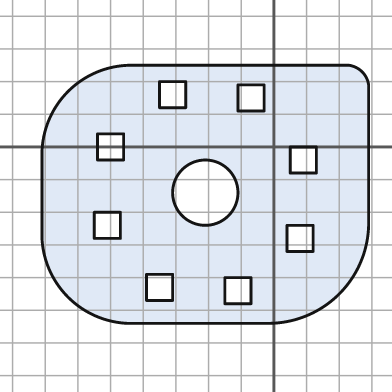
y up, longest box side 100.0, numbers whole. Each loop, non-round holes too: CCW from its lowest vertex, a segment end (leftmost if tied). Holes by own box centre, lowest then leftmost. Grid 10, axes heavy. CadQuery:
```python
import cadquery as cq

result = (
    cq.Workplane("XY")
    .moveTo(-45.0, -54.0)
    .lineTo(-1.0, -54.0)
    .threePointArc((20.0, -45.0), (29.0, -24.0))
    .lineTo(29.0, 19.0)
    .threePointArc((27.0, 23.0), (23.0, 25.0))
    .lineTo(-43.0, 25.0)
    .threePointArc((-63.0, 17.0), (-71.0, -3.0))
    .lineTo(-71.0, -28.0)
    .threePointArc((-63.0, -46.0), (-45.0, -54.0))
    .close()
    .moveTo(-15.0, -48.0)
    .lineTo(-7.0, -48.0)
    .lineTo(-7.0, -40.0)
    .lineTo(-15.0, -40.0)
    .close()
    .moveTo(-39.0, -47.0)
    .lineTo(-31.0, -47.0)
    .lineTo(-31.0, -39.0)
    .lineTo(-39.0, -39.0)
    .close()
    .moveTo(4.0, -32.0)
    .lineTo(12.0, -32.0)
    .lineTo(12.0, -24.0)
    .lineTo(4.0, -24.0)
    .close()
    .moveTo(-55.0, -28.0)
    .lineTo(-47.0, -28.0)
    .lineTo(-47.0, -20.0)
    .lineTo(-55.0, -20.0)
    .close()
    .moveTo(-21.0, -14.0)
    .circle(10.0)
    .moveTo(5.0, -8.0)
    .lineTo(13.0, -8.0)
    .lineTo(13.0, 0.0)
    .lineTo(5.0, 0.0)
    .close()
    .moveTo(-54.0, -4.0)
    .lineTo(-46.0, -4.0)
    .lineTo(-46.0, 4.0)
    .lineTo(-54.0, 4.0)
    .close()
    .moveTo(-11.0, 11.0)
    .lineTo(-3.0, 11.0)
    .lineTo(-3.0, 19.0)
    .lineTo(-11.0, 19.0)
    .close()
    .moveTo(-35.0, 12.0)
    .lineTo(-27.0, 12.0)
    .lineTo(-27.0, 20.0)
    .lineTo(-35.0, 20.0)
    .close()
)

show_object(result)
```